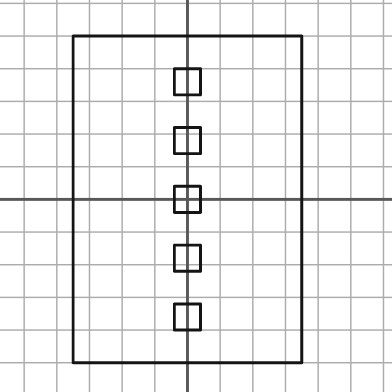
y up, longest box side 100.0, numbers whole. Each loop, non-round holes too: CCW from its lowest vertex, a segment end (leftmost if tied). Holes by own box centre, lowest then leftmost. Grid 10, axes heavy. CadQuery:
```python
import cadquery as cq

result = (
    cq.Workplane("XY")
    .moveTo(-35.0, -50.0)
    .lineTo(35.0, -50.0)
    .lineTo(35.0, 50.0)
    .lineTo(-35.0, 50.0)
    .close()
    .moveTo(-4.0, -40.0)
    .lineTo(4.0, -40.0)
    .lineTo(4.0, -32.0)
    .lineTo(-4.0, -32.0)
    .close()
    .moveTo(-4.0, -22.0)
    .lineTo(4.0, -22.0)
    .lineTo(4.0, -14.0)
    .lineTo(-4.0, -14.0)
    .close()
    .moveTo(-4.0, -4.0)
    .lineTo(4.0, -4.0)
    .lineTo(4.0, 4.0)
    .lineTo(-4.0, 4.0)
    .close()
    .moveTo(-4.0, 14.0)
    .lineTo(4.0, 14.0)
    .lineTo(4.0, 22.0)
    .lineTo(-4.0, 22.0)
    .close()
    .moveTo(-4.0, 32.0)
    .lineTo(4.0, 32.0)
    .lineTo(4.0, 40.0)
    .lineTo(-4.0, 40.0)
    .close()
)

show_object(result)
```